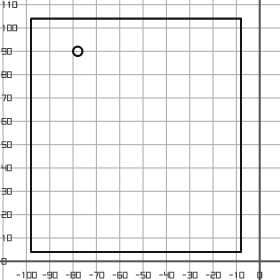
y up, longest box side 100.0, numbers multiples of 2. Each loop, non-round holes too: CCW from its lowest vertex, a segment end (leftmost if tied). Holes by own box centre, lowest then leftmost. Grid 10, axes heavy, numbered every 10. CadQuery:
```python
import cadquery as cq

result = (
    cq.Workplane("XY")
    .moveTo(-98.0, 4.0)
    .lineTo(-8.0, 4.0)
    .lineTo(-8.0, 104.0)
    .lineTo(-98.0, 104.0)
    .close()
    .moveTo(-78.0, 90.0)
    .circle(2.0)
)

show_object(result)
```